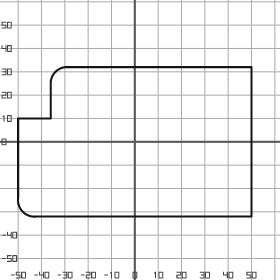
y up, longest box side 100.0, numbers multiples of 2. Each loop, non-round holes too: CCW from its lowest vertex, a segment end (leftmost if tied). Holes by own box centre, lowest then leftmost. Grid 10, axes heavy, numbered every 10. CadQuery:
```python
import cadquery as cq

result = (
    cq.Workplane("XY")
    .moveTo(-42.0, -32.0)
    .lineTo(50.0, -32.0)
    .lineTo(50.0, 32.0)
    .lineTo(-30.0, 32.0)
    .threePointArc((-34.0, 30.0), (-36.0, 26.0))
    .lineTo(-36.0, 10.0)
    .lineTo(-50.0, 10.0)
    .lineTo(-50.0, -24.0)
    .threePointArc((-48.0, -30.0), (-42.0, -32.0))
    .close()
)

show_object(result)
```